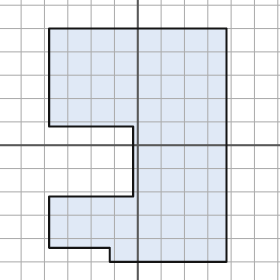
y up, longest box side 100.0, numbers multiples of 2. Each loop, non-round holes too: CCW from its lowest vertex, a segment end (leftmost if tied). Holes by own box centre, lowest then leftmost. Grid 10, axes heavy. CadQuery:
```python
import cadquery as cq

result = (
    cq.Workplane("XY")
    .moveTo(-12.0, -50.0)
    .lineTo(38.0, -50.0)
    .lineTo(38.0, 50.0)
    .lineTo(-38.0, 50.0)
    .lineTo(-38.0, 8.0)
    .lineTo(-2.0, 8.0)
    .lineTo(-2.0, -22.0)
    .lineTo(-38.0, -22.0)
    .lineTo(-38.0, -44.0)
    .lineTo(-12.0, -44.0)
    .close()
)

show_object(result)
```